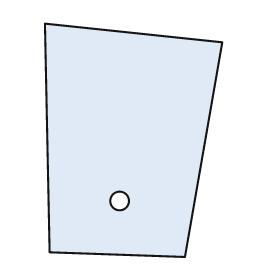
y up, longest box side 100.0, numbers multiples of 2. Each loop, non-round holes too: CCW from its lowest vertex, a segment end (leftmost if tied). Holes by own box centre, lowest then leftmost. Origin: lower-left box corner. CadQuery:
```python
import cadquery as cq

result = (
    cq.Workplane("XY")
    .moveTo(60.0, 0.0)
    .lineTo(76.0, 92.0)
    .lineTo(0.0, 100.0)
    .lineTo(2.0, 2.0)
    .close()
    .moveTo(32.0, 24.0)
    .circle(4.0)
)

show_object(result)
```